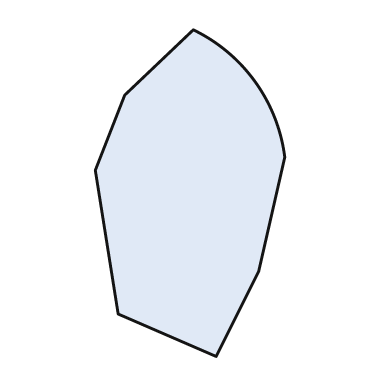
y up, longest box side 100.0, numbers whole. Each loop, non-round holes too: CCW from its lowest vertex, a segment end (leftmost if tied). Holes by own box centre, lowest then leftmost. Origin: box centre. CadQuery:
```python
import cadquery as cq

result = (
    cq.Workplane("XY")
    .moveTo(8.0, -50.0)
    .lineTo(21.0, -24.0)
    .lineTo(29.0, 11.0)
    .threePointArc((20.0, 34.0), (1.0, 50.0))
    .lineTo(-20.0, 30.0)
    .lineTo(-29.0, 7.0)
    .lineTo(-22.0, -37.0)
    .close()
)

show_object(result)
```